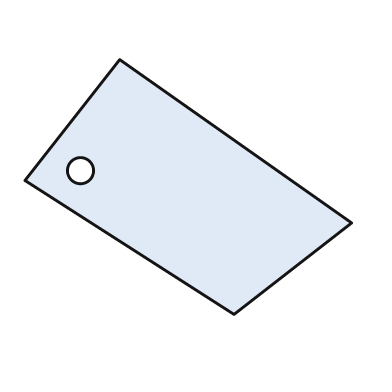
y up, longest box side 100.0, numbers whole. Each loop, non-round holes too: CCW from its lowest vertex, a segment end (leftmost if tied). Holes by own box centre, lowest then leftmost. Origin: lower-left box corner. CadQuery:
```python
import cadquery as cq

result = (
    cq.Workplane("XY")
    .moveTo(64.0, 0.0)
    .lineTo(100.0, 28.0)
    .lineTo(29.0, 78.0)
    .lineTo(0.0, 41.0)
    .close()
    .moveTo(17.0, 44.0)
    .circle(4.0)
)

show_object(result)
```